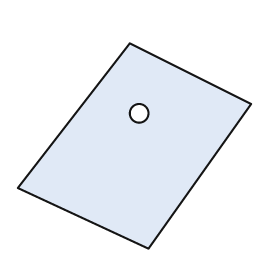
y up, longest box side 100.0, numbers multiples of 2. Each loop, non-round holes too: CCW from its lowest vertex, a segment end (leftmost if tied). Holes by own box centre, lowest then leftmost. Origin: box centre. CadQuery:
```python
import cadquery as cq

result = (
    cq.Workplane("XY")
    .moveTo(6.0, -44.0)
    .lineTo(50.0, 18.0)
    .lineTo(-2.0, 44.0)
    .lineTo(-50.0, -18.0)
    .close()
    .moveTo(2.0, 14.0)
    .circle(4.0)
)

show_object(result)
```